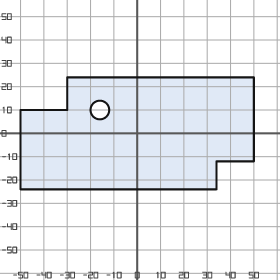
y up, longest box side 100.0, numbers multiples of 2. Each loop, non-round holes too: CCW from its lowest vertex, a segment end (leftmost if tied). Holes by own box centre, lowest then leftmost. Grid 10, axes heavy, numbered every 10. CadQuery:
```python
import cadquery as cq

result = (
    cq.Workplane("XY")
    .moveTo(-50.0, -24.0)
    .lineTo(34.0, -24.0)
    .lineTo(34.0, -12.0)
    .lineTo(50.0, -12.0)
    .lineTo(50.0, 24.0)
    .lineTo(-30.0, 24.0)
    .lineTo(-30.0, 10.0)
    .lineTo(-50.0, 10.0)
    .close()
    .moveTo(-16.0, 10.0)
    .circle(4.0)
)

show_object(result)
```